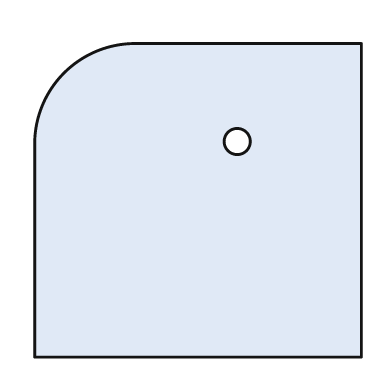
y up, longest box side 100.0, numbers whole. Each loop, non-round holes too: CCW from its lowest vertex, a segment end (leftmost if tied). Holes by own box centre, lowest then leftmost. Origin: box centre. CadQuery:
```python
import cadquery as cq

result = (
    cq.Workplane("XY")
    .moveTo(-50.0, -48.0)
    .lineTo(50.0, -48.0)
    .lineTo(50.0, 48.0)
    .lineTo(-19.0, 48.0)
    .threePointArc((-41.0, 39.0), (-50.0, 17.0))
    .close()
    .moveTo(12.0, 18.0)
    .circle(4.0)
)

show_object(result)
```